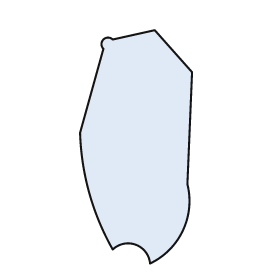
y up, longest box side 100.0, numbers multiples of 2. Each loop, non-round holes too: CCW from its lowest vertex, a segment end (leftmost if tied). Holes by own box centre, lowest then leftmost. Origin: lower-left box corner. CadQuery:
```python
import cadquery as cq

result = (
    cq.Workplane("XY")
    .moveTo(30.0, 0.0)
    .threePointArc((44.0, 14.0), (46.0, 34.0))
    .lineTo(48.0, 82.0)
    .lineTo(32.0, 100.0)
    .lineTo(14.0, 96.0)
    .threePointArc((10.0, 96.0), (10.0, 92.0))
    .lineTo(0.0, 56.0)
    .threePointArc((4.0, 30.0), (14.0, 6.0))
    .threePointArc((24.0, 8.0), (30.0, 0.0))
    .close()
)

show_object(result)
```